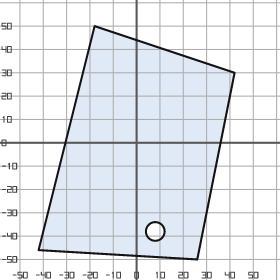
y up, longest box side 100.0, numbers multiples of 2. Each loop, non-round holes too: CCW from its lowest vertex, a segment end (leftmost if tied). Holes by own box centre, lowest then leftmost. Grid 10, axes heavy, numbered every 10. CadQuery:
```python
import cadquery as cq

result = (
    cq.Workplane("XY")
    .moveTo(26.0, -50.0)
    .lineTo(42.0, 30.0)
    .lineTo(-18.0, 50.0)
    .lineTo(-42.0, -46.0)
    .close()
    .moveTo(8.0, -38.0)
    .circle(4.0)
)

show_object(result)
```